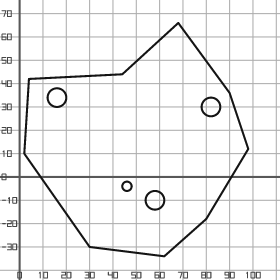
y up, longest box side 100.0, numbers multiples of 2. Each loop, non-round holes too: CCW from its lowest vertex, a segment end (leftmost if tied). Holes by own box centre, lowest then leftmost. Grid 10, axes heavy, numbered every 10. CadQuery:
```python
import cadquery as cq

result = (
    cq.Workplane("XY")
    .moveTo(62.0, -34.0)
    .lineTo(80.0, -18.0)
    .lineTo(98.0, 12.0)
    .lineTo(90.0, 36.0)
    .lineTo(68.0, 66.0)
    .lineTo(44.0, 44.0)
    .lineTo(4.0, 42.0)
    .lineTo(2.0, 10.0)
    .lineTo(30.0, -30.0)
    .close()
    .moveTo(58.0, -10.0)
    .circle(4.0)
    .moveTo(46.0, -4.0)
    .circle(2.0)
    .moveTo(82.0, 30.0)
    .circle(4.0)
    .moveTo(16.0, 34.0)
    .circle(4.0)
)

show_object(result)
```